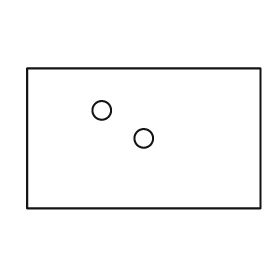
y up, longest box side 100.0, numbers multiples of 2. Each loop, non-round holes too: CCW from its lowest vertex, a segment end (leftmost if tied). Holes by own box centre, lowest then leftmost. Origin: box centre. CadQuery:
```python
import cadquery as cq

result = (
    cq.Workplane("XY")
    .moveTo(-50.0, -30.0)
    .lineTo(50.0, -30.0)
    .lineTo(50.0, 30.0)
    .lineTo(-50.0, 30.0)
    .close()
    .moveTo(0.0, 0.0)
    .circle(4.0)
    .moveTo(-18.0, 12.0)
    .circle(4.0)
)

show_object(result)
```